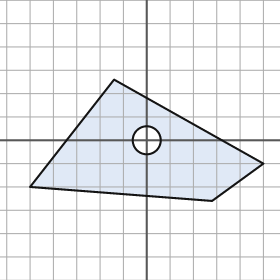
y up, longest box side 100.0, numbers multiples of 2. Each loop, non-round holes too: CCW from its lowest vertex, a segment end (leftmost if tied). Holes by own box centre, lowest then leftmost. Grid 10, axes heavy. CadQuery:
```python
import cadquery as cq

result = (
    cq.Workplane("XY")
    .moveTo(28.0, -26.0)
    .lineTo(50.0, -10.0)
    .lineTo(-14.0, 26.0)
    .lineTo(-50.0, -20.0)
    .close()
    .moveTo(0.0, 0.0)
    .circle(6.0)
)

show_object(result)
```